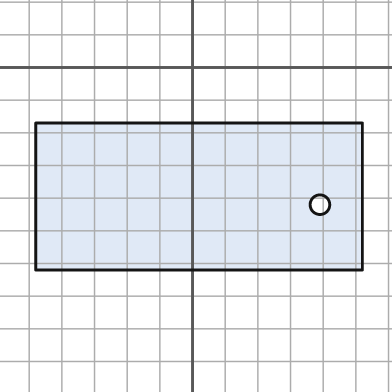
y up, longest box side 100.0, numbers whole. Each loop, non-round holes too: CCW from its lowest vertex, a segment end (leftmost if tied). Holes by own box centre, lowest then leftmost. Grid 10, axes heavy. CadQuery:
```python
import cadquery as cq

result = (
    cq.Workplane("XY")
    .moveTo(-48.0, -62.0)
    .lineTo(52.0, -62.0)
    .lineTo(52.0, -17.0)
    .lineTo(-48.0, -17.0)
    .close()
    .moveTo(39.0, -42.0)
    .circle(3.0)
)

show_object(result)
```